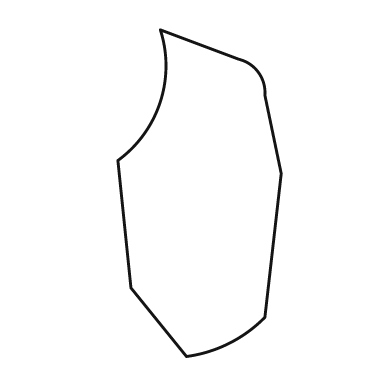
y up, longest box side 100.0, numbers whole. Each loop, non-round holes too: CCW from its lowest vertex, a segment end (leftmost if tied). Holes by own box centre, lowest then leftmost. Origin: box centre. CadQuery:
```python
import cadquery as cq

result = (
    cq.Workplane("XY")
    .moveTo(-4.0, -50.0)
    .threePointArc((9.0, -46.0), (20.0, -38.0))
    .lineTo(25.0, 6.0)
    .lineTo(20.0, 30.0)
    .threePointArc((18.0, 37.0), (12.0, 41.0))
    .lineTo(-12.0, 50.0)
    .threePointArc((-12.0, 28.0), (-25.0, 10.0))
    .lineTo(-21.0, -29.0)
    .close()
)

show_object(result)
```